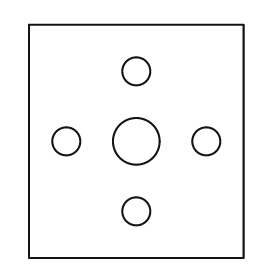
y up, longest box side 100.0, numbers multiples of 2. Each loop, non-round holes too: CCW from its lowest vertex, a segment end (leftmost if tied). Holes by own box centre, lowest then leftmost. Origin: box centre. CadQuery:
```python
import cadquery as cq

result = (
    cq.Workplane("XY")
    .moveTo(-46.0, -50.0)
    .lineTo(46.0, -50.0)
    .lineTo(46.0, 50.0)
    .lineTo(-46.0, 50.0)
    .close()
    .moveTo(0.0, -30.0)
    .circle(6.0)
    .moveTo(-30.0, 0.0)
    .circle(6.0)
    .moveTo(0.0, 0.0)
    .circle(10.0)
    .moveTo(30.0, 0.0)
    .circle(6.0)
    .moveTo(0.0, 30.0)
    .circle(6.0)
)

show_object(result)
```